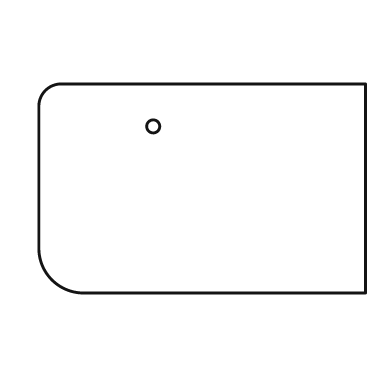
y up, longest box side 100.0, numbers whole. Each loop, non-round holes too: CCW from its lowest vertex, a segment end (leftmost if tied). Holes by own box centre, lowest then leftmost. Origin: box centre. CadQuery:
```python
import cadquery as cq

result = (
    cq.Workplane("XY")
    .moveTo(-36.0, -32.0)
    .lineTo(50.0, -32.0)
    .lineTo(50.0, 32.0)
    .lineTo(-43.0, 32.0)
    .threePointArc((-48.0, 30.0), (-50.0, 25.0))
    .lineTo(-50.0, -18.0)
    .threePointArc((-46.0, -28.0), (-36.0, -32.0))
    .close()
    .moveTo(-15.0, 19.0)
    .circle(2.0)
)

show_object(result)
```